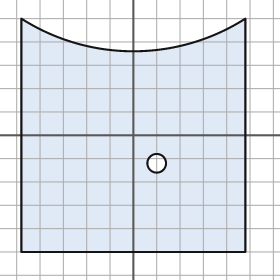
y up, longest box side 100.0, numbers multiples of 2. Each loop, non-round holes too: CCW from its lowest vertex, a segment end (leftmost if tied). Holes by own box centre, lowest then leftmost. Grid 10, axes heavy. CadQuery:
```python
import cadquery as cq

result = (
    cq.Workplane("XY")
    .moveTo(-48.0, -50.0)
    .lineTo(48.0, -50.0)
    .lineTo(48.0, 50.0)
    .threePointArc((0.0, 36.0), (-48.0, 50.0))
    .close()
    .moveTo(10.0, -12.0)
    .circle(4.0)
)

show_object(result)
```